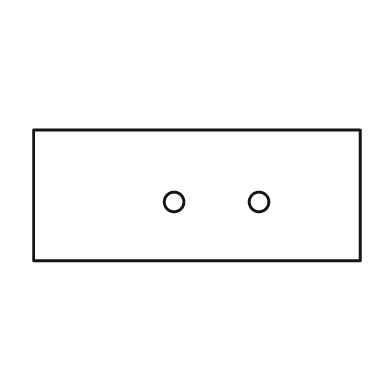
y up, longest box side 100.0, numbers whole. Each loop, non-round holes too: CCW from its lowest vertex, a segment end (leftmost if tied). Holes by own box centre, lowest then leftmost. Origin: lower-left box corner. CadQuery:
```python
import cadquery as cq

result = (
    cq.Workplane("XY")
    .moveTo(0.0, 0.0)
    .lineTo(100.0, 0.0)
    .lineTo(100.0, 40.0)
    .lineTo(0.0, 40.0)
    .close()
    .moveTo(43.0, 18.0)
    .circle(3.0)
    .moveTo(69.0, 18.0)
    .circle(3.0)
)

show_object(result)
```